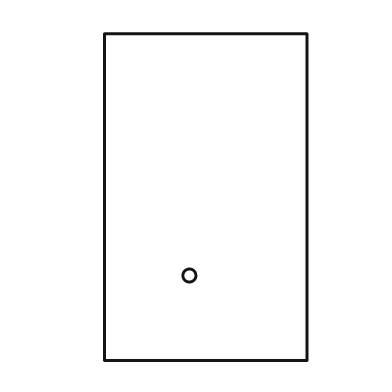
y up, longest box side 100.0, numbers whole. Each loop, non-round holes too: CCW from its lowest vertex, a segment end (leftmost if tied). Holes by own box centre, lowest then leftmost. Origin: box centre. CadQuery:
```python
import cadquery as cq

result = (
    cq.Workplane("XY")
    .moveTo(-31.0, -50.0)
    .lineTo(31.0, -50.0)
    .lineTo(31.0, 50.0)
    .lineTo(-31.0, 50.0)
    .close()
    .moveTo(-5.0, -24.0)
    .circle(2.0)
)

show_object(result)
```